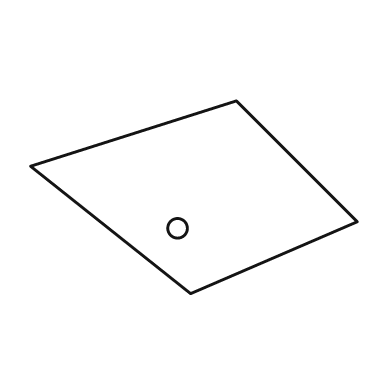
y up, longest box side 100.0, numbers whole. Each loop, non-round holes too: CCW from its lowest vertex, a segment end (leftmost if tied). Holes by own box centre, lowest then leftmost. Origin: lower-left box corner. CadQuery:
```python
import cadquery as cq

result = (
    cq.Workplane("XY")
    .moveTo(49.0, 0.0)
    .lineTo(100.0, 22.0)
    .lineTo(63.0, 59.0)
    .lineTo(0.0, 39.0)
    .close()
    .moveTo(45.0, 20.0)
    .circle(3.0)
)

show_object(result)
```